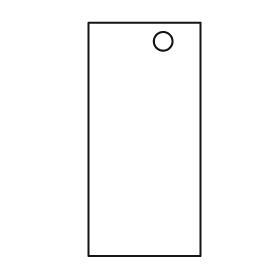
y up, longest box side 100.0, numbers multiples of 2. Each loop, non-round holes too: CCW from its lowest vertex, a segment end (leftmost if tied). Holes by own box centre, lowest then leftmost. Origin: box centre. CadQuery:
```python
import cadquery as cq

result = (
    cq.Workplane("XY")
    .moveTo(-24.0, -50.0)
    .lineTo(24.0, -50.0)
    .lineTo(24.0, 50.0)
    .lineTo(-24.0, 50.0)
    .close()
    .moveTo(8.0, 42.0)
    .circle(4.0)
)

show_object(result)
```